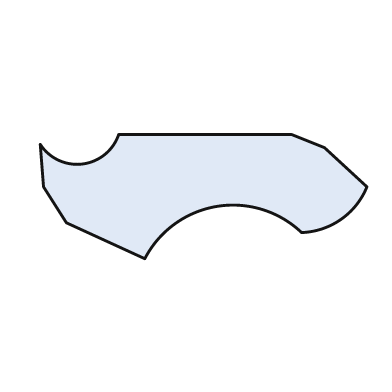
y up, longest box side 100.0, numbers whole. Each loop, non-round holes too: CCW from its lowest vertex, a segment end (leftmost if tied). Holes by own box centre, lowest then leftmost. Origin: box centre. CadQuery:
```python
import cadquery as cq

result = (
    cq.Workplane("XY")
    .moveTo(-18.0, -19.0)
    .threePointArc((4.0, -3.0), (30.0, -11.0))
    .threePointArc((42.0, -7.0), (50.0, 3.0))
    .lineTo(37.0, 15.0)
    .lineTo(27.0, 19.0)
    .lineTo(-26.0, 19.0)
    .threePointArc((-37.0, 10.0), (-50.0, 16.0))
    .lineTo(-49.0, 3.0)
    .lineTo(-42.0, -8.0)
    .close()
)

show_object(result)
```